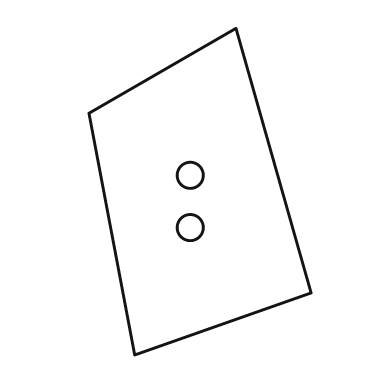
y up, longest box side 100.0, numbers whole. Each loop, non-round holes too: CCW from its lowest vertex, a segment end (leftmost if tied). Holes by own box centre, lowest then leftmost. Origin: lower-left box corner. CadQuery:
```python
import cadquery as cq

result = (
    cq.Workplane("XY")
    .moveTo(14.0, 0.0)
    .lineTo(68.0, 19.0)
    .lineTo(45.0, 100.0)
    .lineTo(0.0, 74.0)
    .close()
    .moveTo(31.0, 39.0)
    .circle(4.0)
    .moveTo(31.0, 55.0)
    .circle(4.0)
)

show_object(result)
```